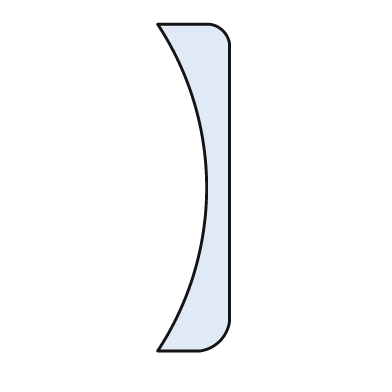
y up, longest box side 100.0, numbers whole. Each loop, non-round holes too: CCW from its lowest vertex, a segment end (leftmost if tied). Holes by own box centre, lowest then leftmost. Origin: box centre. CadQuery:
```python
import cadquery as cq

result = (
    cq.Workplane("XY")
    .moveTo(-11.0, -50.0)
    .lineTo(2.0, -50.0)
    .threePointArc((8.0, -47.0), (11.0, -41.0))
    .lineTo(11.0, 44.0)
    .threePointArc((9.0, 48.0), (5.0, 50.0))
    .lineTo(-11.0, 50.0)
    .threePointArc((4.0, 0.0), (-11.0, -50.0))
    .close()
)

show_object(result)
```